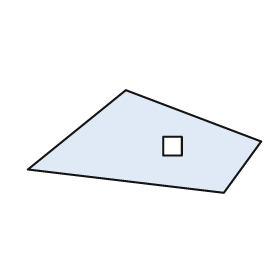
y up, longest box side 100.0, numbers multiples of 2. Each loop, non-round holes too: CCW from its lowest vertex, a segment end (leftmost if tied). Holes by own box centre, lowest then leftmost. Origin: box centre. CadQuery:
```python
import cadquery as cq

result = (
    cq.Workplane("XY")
    .moveTo(34.0, -22.0)
    .lineTo(50.0, 0.0)
    .lineTo(-8.0, 22.0)
    .lineTo(-50.0, -12.0)
    .close()
    .moveTo(8.0, -6.0)
    .lineTo(16.0, -6.0)
    .lineTo(16.0, 2.0)
    .lineTo(8.0, 2.0)
    .close()
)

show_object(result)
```